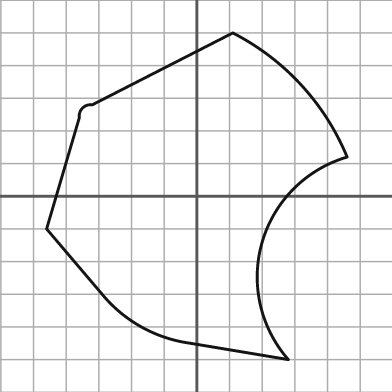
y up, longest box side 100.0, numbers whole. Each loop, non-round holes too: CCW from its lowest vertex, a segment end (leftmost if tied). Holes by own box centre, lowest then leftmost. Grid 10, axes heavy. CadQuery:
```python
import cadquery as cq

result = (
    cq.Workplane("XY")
    .moveTo(28.0, -50.0)
    .threePointArc((20.0, -14.0), (46.0, 12.0))
    .threePointArc((32.0, 34.0), (11.0, 50.0))
    .lineTo(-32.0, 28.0)
    .threePointArc((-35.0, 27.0), (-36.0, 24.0))
    .lineTo(-46.0, -10.0)
    .lineTo(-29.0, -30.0)
    .threePointArc((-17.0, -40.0), (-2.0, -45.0))
    .close()
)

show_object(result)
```